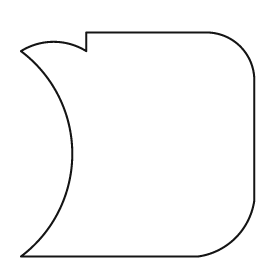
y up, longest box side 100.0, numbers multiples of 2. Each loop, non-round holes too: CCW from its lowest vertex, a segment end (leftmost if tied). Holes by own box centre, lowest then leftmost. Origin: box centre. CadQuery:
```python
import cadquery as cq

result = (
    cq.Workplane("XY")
    .moveTo(-50.0, -48.0)
    .lineTo(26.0, -48.0)
    .threePointArc((42.0, -40.0), (50.0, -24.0))
    .lineTo(50.0, 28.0)
    .threePointArc((44.0, 42.0), (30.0, 48.0))
    .lineTo(-22.0, 48.0)
    .lineTo(-22.0, 40.0)
    .threePointArc((-36.0, 44.0), (-50.0, 40.0))
    .threePointArc((-28.0, -4.0), (-50.0, -48.0))
    .close()
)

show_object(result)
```